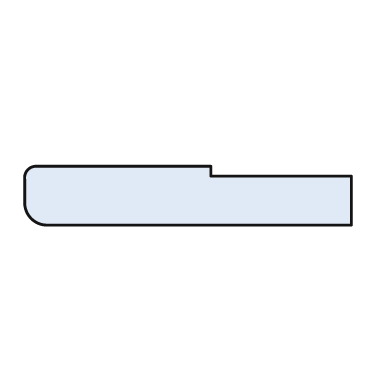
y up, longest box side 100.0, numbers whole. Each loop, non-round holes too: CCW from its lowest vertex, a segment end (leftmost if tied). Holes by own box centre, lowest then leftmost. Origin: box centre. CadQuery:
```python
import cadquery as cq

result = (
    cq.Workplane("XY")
    .moveTo(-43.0, -9.0)
    .lineTo(50.0, -9.0)
    .lineTo(50.0, 6.0)
    .lineTo(7.0, 6.0)
    .lineTo(7.0, 9.0)
    .lineTo(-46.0, 9.0)
    .threePointArc((-49.0, 8.0), (-50.0, 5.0))
    .lineTo(-50.0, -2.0)
    .threePointArc((-48.0, -7.0), (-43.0, -9.0))
    .close()
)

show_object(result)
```